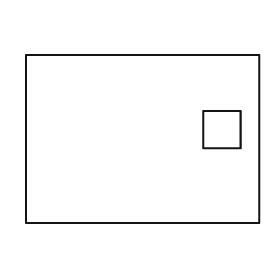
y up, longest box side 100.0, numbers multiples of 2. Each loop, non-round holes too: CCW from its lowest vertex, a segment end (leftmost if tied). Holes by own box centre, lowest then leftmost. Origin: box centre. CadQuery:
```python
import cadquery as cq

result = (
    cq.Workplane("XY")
    .moveTo(-50.0, -36.0)
    .lineTo(50.0, -36.0)
    .lineTo(50.0, 36.0)
    .lineTo(-50.0, 36.0)
    .close()
    .moveTo(26.0, -4.0)
    .lineTo(42.0, -4.0)
    .lineTo(42.0, 12.0)
    .lineTo(26.0, 12.0)
    .close()
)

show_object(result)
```